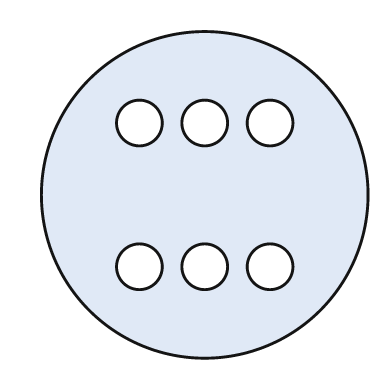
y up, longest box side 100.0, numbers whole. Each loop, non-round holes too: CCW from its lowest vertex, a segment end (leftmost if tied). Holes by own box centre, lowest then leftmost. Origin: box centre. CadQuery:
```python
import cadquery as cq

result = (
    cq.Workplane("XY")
    .moveTo(0.0, 0.0)
    .circle(50.0)
    .moveTo(-20.0, -22.0)
    .circle(7.0)
    .moveTo(0.0, -22.0)
    .circle(7.0)
    .moveTo(20.0, -22.0)
    .circle(7.0)
    .moveTo(-20.0, 22.0)
    .circle(7.0)
    .moveTo(0.0, 22.0)
    .circle(7.0)
    .moveTo(20.0, 22.0)
    .circle(7.0)
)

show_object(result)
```